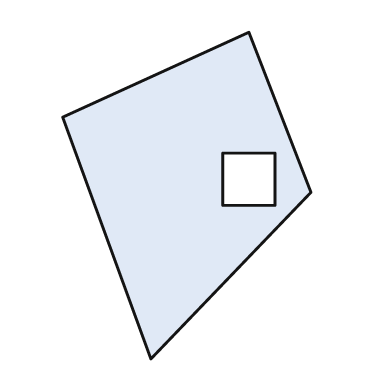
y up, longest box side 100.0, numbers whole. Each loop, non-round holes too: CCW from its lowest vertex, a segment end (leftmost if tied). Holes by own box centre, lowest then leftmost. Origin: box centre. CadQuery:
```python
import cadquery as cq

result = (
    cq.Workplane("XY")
    .moveTo(-11.0, -50.0)
    .lineTo(38.0, 1.0)
    .lineTo(19.0, 50.0)
    .lineTo(-38.0, 24.0)
    .close()
    .moveTo(11.0, -3.0)
    .lineTo(27.0, -3.0)
    .lineTo(27.0, 13.0)
    .lineTo(11.0, 13.0)
    .close()
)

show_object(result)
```